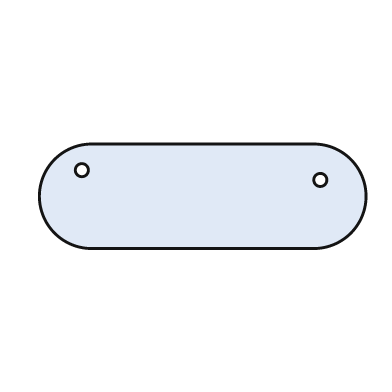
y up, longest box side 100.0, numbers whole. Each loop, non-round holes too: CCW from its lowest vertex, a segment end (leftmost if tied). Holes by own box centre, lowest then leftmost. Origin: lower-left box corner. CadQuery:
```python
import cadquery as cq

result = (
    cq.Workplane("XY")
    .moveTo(16.0, 0.0)
    .lineTo(84.0, 0.0)
    .threePointArc((100.0, 16.0), (84.0, 32.0))
    .lineTo(16.0, 32.0)
    .threePointArc((0.0, 16.0), (16.0, 0.0))
    .close()
    .moveTo(86.0, 21.0)
    .circle(2.0)
    .moveTo(13.0, 24.0)
    .circle(2.0)
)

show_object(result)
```